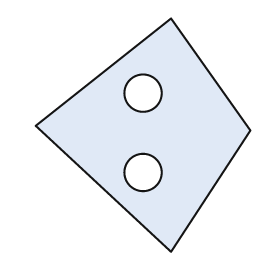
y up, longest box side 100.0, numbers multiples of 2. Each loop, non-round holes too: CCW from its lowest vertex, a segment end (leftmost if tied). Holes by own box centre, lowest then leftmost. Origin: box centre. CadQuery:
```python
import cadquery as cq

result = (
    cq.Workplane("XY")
    .moveTo(12.0, -50.0)
    .lineTo(46.0, 2.0)
    .lineTo(12.0, 50.0)
    .lineTo(-46.0, 4.0)
    .close()
    .moveTo(0.0, -16.0)
    .circle(8.0)
    .moveTo(0.0, 18.0)
    .circle(8.0)
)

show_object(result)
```